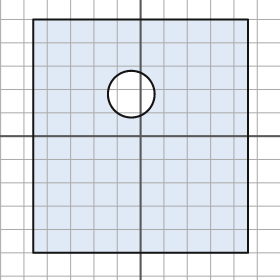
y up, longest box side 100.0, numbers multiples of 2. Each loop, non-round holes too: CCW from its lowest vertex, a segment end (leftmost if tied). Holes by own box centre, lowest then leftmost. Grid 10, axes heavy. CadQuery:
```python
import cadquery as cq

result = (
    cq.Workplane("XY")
    .moveTo(-46.0, -50.0)
    .lineTo(46.0, -50.0)
    .lineTo(46.0, 50.0)
    .lineTo(-46.0, 50.0)
    .close()
    .moveTo(-4.0, 18.0)
    .circle(10.0)
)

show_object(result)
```